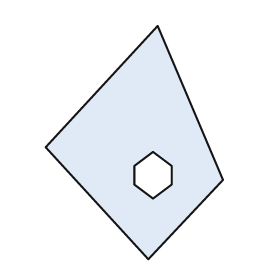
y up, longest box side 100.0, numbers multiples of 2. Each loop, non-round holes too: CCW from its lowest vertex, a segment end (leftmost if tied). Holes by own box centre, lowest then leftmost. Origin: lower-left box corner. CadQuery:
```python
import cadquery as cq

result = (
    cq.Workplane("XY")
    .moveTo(44.0, 0.0)
    .lineTo(76.0, 34.0)
    .lineTo(48.0, 100.0)
    .lineTo(0.0, 48.0)
    .close()
    .moveTo(46.0, 26.0)
    .lineTo(54.0, 32.0)
    .lineTo(54.0, 40.0)
    .lineTo(46.0, 46.0)
    .lineTo(38.0, 40.0)
    .lineTo(38.0, 32.0)
    .close()
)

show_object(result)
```